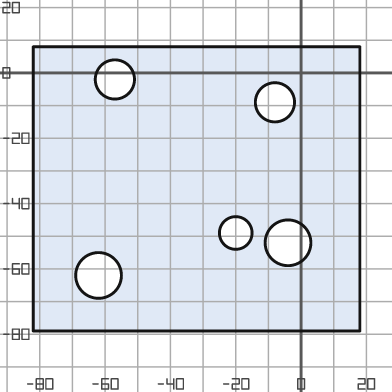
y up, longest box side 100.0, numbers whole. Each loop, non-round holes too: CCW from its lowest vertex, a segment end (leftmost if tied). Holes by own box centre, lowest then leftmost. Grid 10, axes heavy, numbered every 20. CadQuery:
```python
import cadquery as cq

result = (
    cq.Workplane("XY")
    .moveTo(-82.0, -79.0)
    .lineTo(18.0, -79.0)
    .lineTo(18.0, 8.0)
    .lineTo(-82.0, 8.0)
    .close()
    .moveTo(-62.0, -62.0)
    .circle(7.0)
    .moveTo(-4.0, -52.0)
    .circle(7.0)
    .moveTo(-20.0, -49.0)
    .circle(5.0)
    .moveTo(-8.0, -9.0)
    .circle(6.0)
    .moveTo(-57.0, -2.0)
    .circle(6.0)
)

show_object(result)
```